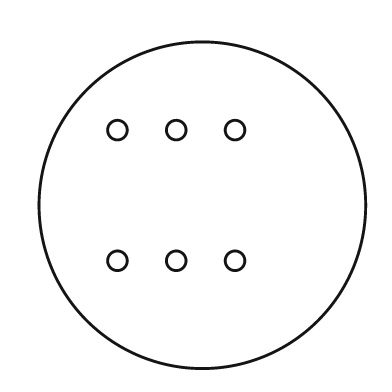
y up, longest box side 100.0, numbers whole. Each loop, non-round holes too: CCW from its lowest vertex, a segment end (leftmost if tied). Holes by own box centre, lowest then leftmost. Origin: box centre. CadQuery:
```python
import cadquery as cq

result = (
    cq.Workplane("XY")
    .moveTo(0.0, 0.0)
    .circle(50.0)
    .moveTo(-26.0, -17.0)
    .circle(3.0)
    .moveTo(-8.0, -17.0)
    .circle(3.0)
    .moveTo(10.0, -17.0)
    .circle(3.0)
    .moveTo(-26.0, 23.0)
    .circle(3.0)
    .moveTo(-8.0, 23.0)
    .circle(3.0)
    .moveTo(10.0, 23.0)
    .circle(3.0)
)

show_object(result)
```